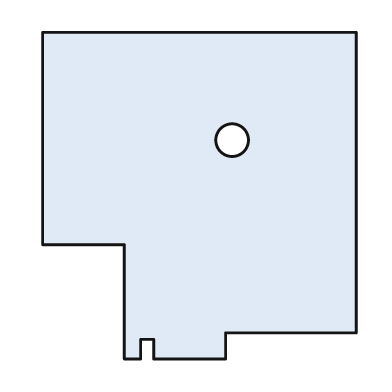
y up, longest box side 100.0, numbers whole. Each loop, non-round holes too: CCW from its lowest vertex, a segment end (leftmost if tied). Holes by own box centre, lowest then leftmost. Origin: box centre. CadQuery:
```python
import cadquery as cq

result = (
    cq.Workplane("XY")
    .moveTo(-23.0, -50.0)
    .lineTo(-18.0, -50.0)
    .lineTo(-18.0, -44.0)
    .lineTo(-14.0, -44.0)
    .lineTo(-14.0, -50.0)
    .lineTo(8.0, -50.0)
    .lineTo(8.0, -42.0)
    .lineTo(48.0, -42.0)
    .lineTo(48.0, 50.0)
    .lineTo(-48.0, 50.0)
    .lineTo(-48.0, -15.0)
    .lineTo(-23.0, -15.0)
    .close()
    .moveTo(10.0, 17.0)
    .circle(5.0)
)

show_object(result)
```